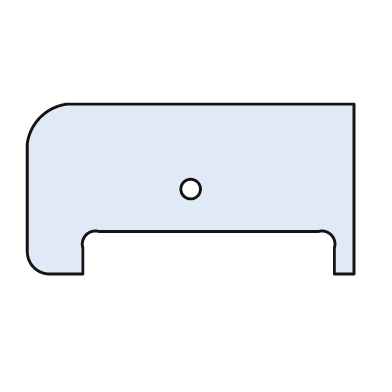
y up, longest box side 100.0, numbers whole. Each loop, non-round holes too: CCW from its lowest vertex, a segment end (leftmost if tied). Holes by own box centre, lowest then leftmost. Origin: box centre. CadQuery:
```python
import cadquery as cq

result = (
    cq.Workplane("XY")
    .moveTo(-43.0, -26.0)
    .lineTo(-33.0, -26.0)
    .lineTo(-33.0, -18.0)
    .threePointArc((-32.0, -14.0), (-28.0, -13.0))
    .lineTo(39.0, -13.0)
    .threePointArc((43.0, -14.0), (44.0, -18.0))
    .lineTo(44.0, -26.0)
    .lineTo(50.0, -26.0)
    .lineTo(50.0, 26.0)
    .lineTo(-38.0, 26.0)
    .threePointArc((-46.0, 22.0), (-50.0, 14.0))
    .lineTo(-50.0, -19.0)
    .threePointArc((-48.0, -24.0), (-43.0, -26.0))
    .close()
    .moveTo(0.0, 0.0)
    .circle(3.0)
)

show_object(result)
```